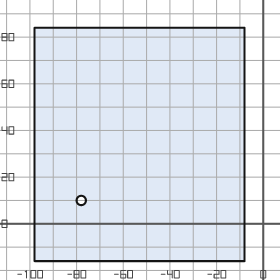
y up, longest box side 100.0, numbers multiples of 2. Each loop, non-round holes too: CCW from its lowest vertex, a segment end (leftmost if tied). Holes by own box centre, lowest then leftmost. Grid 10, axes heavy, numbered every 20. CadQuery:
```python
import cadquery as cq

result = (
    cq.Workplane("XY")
    .moveTo(-98.0, -16.0)
    .lineTo(-8.0, -16.0)
    .lineTo(-8.0, 84.0)
    .lineTo(-98.0, 84.0)
    .close()
    .moveTo(-78.0, 10.0)
    .circle(2.0)
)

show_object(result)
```